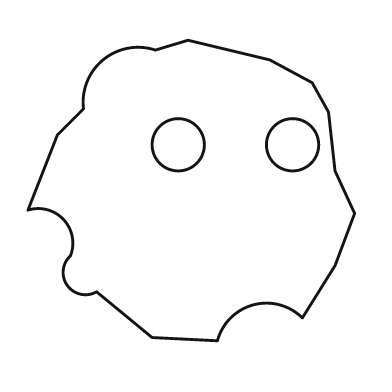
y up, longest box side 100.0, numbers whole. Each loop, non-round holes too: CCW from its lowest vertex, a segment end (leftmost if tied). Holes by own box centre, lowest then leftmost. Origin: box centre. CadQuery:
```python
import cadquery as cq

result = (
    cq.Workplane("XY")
    .moveTo(8.0, -46.0)
    .threePointArc((19.0, -35.0), (34.0, -39.0))
    .lineTo(44.0, -23.0)
    .lineTo(50.0, -7.0)
    .lineTo(44.0, 6.0)
    .lineTo(42.0, 24.0)
    .lineTo(37.0, 33.0)
    .lineTo(24.0, 40.0)
    .lineTo(-1.0, 46.0)
    .lineTo(-11.0, 43.0)
    .threePointArc((-27.0, 40.0), (-33.0, 25.0))
    .lineTo(-41.0, 17.0)
    .lineTo(-50.0, -6.0)
    .threePointArc((-39.0, -9.0), (-37.0, -20.0))
    .threePointArc((-38.0, -29.0), (-29.0, -31.0))
    .lineTo(-12.0, -45.0)
    .close()
    .moveTo(-4.0, 14.0)
    .circle(8.0)
    .moveTo(31.0, 14.0)
    .circle(8.0)
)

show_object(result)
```